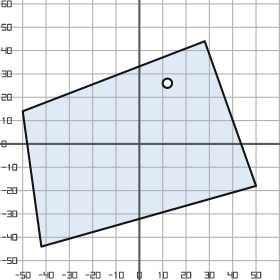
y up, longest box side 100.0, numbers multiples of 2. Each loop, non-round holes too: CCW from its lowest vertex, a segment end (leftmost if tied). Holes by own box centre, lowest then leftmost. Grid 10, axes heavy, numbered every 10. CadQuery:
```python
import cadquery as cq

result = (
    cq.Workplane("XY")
    .moveTo(-42.0, -44.0)
    .lineTo(50.0, -18.0)
    .lineTo(28.0, 44.0)
    .lineTo(-50.0, 14.0)
    .close()
    .moveTo(12.0, 26.0)
    .circle(2.0)
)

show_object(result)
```